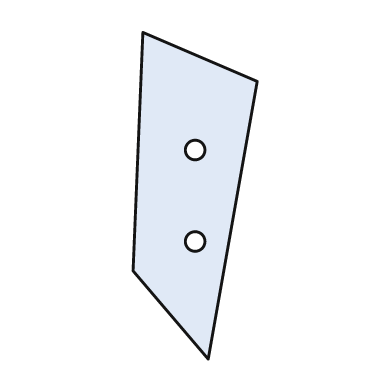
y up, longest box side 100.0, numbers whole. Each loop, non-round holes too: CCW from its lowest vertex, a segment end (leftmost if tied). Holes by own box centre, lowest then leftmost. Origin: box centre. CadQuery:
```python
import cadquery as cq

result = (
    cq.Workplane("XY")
    .moveTo(4.0, -50.0)
    .lineTo(19.0, 35.0)
    .lineTo(-16.0, 50.0)
    .lineTo(-19.0, -23.0)
    .close()
    .moveTo(0.0, -14.0)
    .circle(3.0)
    .moveTo(0.0, 14.0)
    .circle(3.0)
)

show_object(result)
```